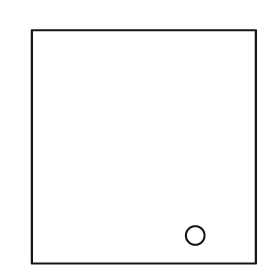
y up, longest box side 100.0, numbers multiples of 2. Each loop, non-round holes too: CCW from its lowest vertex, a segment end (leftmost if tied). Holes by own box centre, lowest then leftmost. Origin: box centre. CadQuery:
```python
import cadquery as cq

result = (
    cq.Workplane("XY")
    .moveTo(-48.0, -50.0)
    .lineTo(48.0, -50.0)
    .lineTo(48.0, 50.0)
    .lineTo(-48.0, 50.0)
    .close()
    .moveTo(22.0, -38.0)
    .circle(4.0)
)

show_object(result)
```